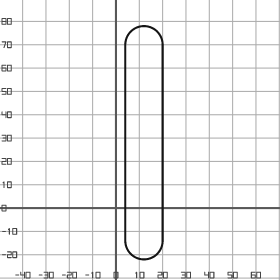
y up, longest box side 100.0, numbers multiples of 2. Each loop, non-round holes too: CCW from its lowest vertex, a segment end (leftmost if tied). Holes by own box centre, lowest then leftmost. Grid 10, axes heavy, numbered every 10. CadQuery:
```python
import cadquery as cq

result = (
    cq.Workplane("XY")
    .moveTo(4.0, -14.0)
    .threePointArc((12.0, -22.0), (20.0, -14.0))
    .lineTo(20.0, 70.0)
    .threePointArc((12.0, 78.0), (4.0, 70.0))
    .close()
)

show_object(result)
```